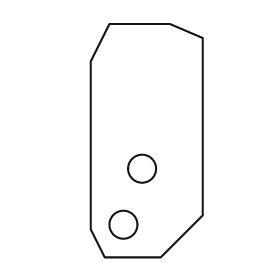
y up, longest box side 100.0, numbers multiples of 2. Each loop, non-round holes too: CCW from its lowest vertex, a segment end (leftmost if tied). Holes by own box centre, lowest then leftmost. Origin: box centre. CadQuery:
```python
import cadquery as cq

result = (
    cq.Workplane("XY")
    .moveTo(-18.0, -50.0)
    .lineTo(6.0, -50.0)
    .lineTo(24.0, -32.0)
    .lineTo(24.0, 44.0)
    .lineTo(10.0, 50.0)
    .lineTo(-16.0, 50.0)
    .lineTo(-24.0, 34.0)
    .lineTo(-24.0, -38.0)
    .close()
    .moveTo(-10.0, -36.0)
    .circle(6.0)
    .moveTo(-2.0, -12.0)
    .circle(6.0)
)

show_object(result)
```